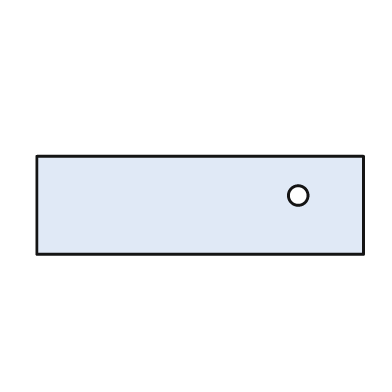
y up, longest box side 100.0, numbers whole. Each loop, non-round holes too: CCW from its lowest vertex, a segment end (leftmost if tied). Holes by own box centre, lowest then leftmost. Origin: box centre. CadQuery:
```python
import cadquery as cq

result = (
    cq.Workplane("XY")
    .moveTo(-50.0, -15.0)
    .lineTo(50.0, -15.0)
    .lineTo(50.0, 15.0)
    .lineTo(-50.0, 15.0)
    .close()
    .moveTo(30.0, 3.0)
    .circle(3.0)
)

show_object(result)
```